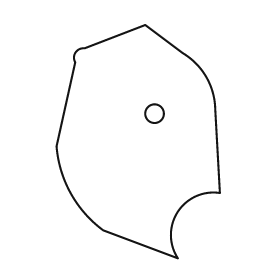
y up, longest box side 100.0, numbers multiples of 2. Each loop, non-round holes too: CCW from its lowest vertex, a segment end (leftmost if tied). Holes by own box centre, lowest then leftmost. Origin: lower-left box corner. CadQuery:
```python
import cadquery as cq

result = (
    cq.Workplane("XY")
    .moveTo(52.0, 0.0)
    .threePointArc((52.0, 20.0), (70.0, 28.0))
    .lineTo(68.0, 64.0)
    .threePointArc((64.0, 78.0), (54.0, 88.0))
    .lineTo(38.0, 100.0)
    .lineTo(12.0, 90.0)
    .threePointArc((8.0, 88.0), (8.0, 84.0))
    .lineTo(0.0, 48.0)
    .threePointArc((6.0, 28.0), (20.0, 12.0))
    .close()
    .moveTo(42.0, 62.0)
    .circle(4.0)
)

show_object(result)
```